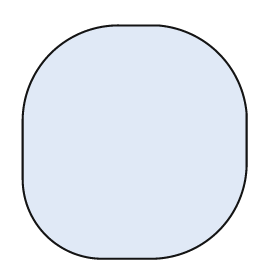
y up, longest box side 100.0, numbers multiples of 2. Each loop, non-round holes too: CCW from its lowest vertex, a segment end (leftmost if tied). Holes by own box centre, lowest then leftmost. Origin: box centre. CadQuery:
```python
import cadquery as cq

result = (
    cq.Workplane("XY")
    .moveTo(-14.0, -50.0)
    .lineTo(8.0, -50.0)
    .threePointArc((36.0, -38.0), (48.0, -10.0))
    .lineTo(48.0, 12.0)
    .threePointArc((36.0, 38.0), (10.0, 50.0))
    .lineTo(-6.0, 50.0)
    .threePointArc((-36.0, 38.0), (-48.0, 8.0))
    .lineTo(-48.0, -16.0)
    .threePointArc((-38.0, -40.0), (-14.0, -50.0))
    .close()
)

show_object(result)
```